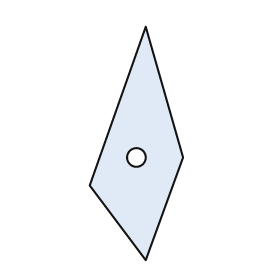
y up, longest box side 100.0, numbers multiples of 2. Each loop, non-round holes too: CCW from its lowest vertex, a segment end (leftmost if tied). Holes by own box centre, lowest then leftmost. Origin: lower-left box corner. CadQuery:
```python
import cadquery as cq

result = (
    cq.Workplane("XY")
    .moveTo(24.0, 0.0)
    .lineTo(40.0, 44.0)
    .lineTo(24.0, 100.0)
    .lineTo(0.0, 32.0)
    .close()
    .moveTo(20.0, 44.0)
    .circle(4.0)
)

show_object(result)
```